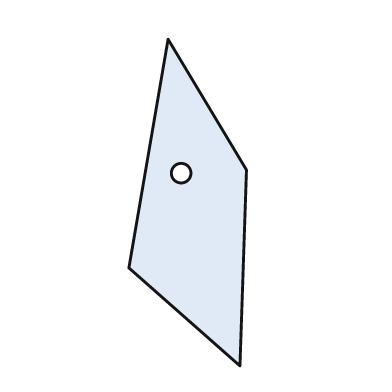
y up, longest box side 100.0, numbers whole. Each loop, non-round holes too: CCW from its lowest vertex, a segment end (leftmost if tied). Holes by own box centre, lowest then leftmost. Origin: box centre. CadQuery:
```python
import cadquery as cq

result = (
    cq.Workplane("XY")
    .moveTo(16.0, -50.0)
    .lineTo(18.0, 10.0)
    .lineTo(-6.0, 50.0)
    .lineTo(-18.0, -20.0)
    .close()
    .moveTo(-2.0, 9.0)
    .circle(3.0)
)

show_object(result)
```